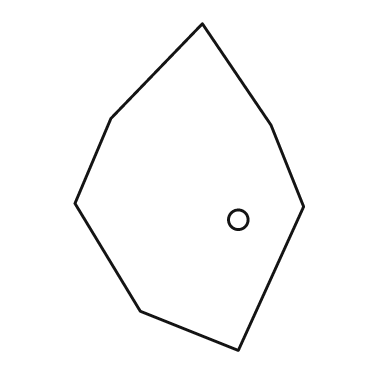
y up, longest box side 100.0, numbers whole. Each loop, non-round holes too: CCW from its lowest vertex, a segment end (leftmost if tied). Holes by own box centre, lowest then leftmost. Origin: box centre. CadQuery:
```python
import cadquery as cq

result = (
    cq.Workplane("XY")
    .moveTo(15.0, -50.0)
    .lineTo(35.0, -6.0)
    .lineTo(25.0, 19.0)
    .lineTo(4.0, 50.0)
    .lineTo(-24.0, 21.0)
    .lineTo(-35.0, -5.0)
    .lineTo(-15.0, -38.0)
    .close()
    .moveTo(15.0, -10.0)
    .circle(3.0)
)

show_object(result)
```